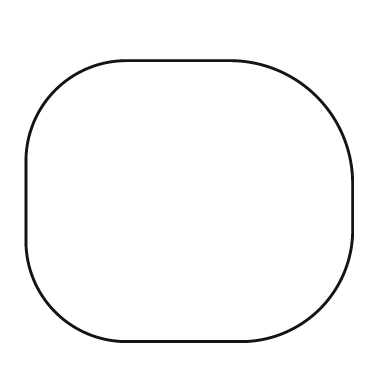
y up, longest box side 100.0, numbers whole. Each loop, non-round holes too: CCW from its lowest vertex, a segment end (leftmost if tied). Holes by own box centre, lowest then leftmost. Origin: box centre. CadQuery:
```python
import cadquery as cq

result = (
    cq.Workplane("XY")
    .moveTo(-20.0, -43.0)
    .lineTo(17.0, -43.0)
    .threePointArc((40.0, -33.0), (50.0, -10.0))
    .lineTo(50.0, 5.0)
    .threePointArc((39.0, 32.0), (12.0, 43.0))
    .lineTo(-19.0, 43.0)
    .threePointArc((-41.0, 34.0), (-50.0, 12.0))
    .lineTo(-50.0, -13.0)
    .threePointArc((-41.0, -34.0), (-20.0, -43.0))
    .close()
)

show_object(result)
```